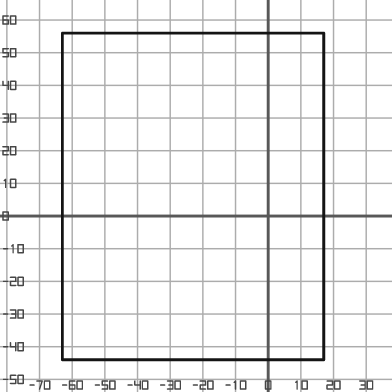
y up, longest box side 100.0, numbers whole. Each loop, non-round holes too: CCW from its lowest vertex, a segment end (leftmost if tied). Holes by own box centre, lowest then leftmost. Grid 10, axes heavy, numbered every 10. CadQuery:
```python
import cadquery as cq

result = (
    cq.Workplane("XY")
    .moveTo(-63.0, -44.0)
    .lineTo(17.0, -44.0)
    .lineTo(17.0, 56.0)
    .lineTo(-63.0, 56.0)
    .close()
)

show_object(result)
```